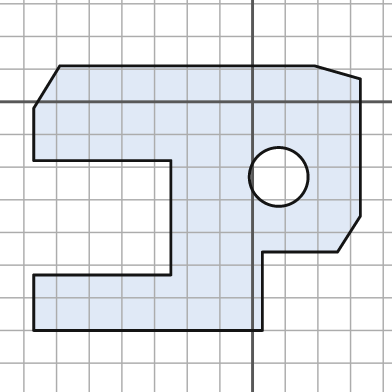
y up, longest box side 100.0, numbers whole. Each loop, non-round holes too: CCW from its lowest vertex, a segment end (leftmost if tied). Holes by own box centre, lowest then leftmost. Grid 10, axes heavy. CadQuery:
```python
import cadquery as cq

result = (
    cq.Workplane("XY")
    .moveTo(-67.0, -70.0)
    .lineTo(3.0, -70.0)
    .lineTo(3.0, -46.0)
    .lineTo(26.0, -46.0)
    .lineTo(33.0, -35.0)
    .lineTo(33.0, 7.0)
    .lineTo(19.0, 11.0)
    .lineTo(-59.0, 11.0)
    .lineTo(-67.0, -2.0)
    .lineTo(-67.0, -18.0)
    .lineTo(-25.0, -18.0)
    .lineTo(-25.0, -53.0)
    .lineTo(-67.0, -53.0)
    .close()
    .moveTo(8.0, -23.0)
    .circle(9.0)
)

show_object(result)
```